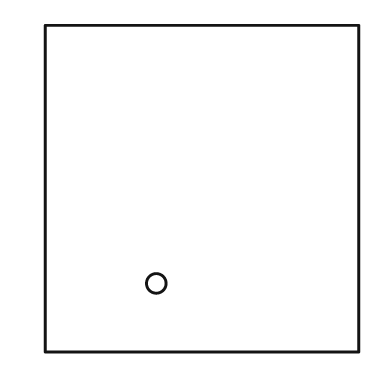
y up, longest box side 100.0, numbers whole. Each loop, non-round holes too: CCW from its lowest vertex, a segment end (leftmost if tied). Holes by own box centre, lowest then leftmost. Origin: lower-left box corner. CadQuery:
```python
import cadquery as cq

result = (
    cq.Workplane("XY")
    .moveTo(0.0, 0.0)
    .lineTo(96.0, 0.0)
    .lineTo(96.0, 100.0)
    .lineTo(0.0, 100.0)
    .close()
    .moveTo(34.0, 21.0)
    .circle(3.0)
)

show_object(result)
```